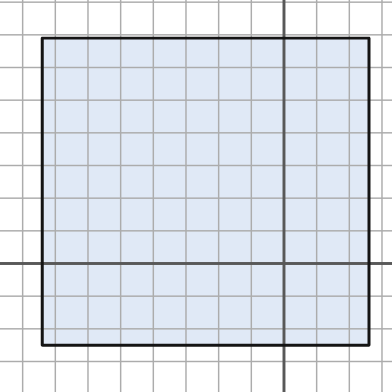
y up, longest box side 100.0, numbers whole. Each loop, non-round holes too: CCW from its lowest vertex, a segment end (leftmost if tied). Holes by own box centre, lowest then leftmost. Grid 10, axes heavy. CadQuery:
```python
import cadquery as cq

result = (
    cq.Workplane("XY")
    .moveTo(-74.0, -25.0)
    .lineTo(26.0, -25.0)
    .lineTo(26.0, 69.0)
    .lineTo(-74.0, 69.0)
    .close()
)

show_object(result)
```